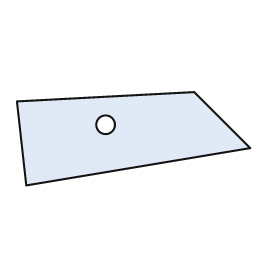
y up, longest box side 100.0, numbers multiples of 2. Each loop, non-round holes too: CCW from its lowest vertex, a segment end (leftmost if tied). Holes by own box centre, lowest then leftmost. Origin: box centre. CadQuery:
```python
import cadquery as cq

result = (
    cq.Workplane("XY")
    .moveTo(-46.0, -20.0)
    .lineTo(50.0, -4.0)
    .lineTo(26.0, 20.0)
    .lineTo(-50.0, 16.0)
    .close()
    .moveTo(-12.0, 6.0)
    .circle(4.0)
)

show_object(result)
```